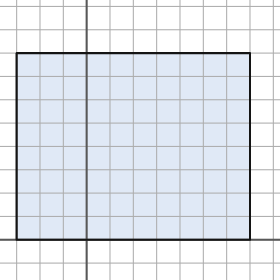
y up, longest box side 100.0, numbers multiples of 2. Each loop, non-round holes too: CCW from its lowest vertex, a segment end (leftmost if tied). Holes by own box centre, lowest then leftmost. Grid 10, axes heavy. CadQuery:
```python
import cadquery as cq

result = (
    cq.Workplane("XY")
    .moveTo(-30.0, 0.0)
    .lineTo(70.0, 0.0)
    .lineTo(70.0, 80.0)
    .lineTo(-30.0, 80.0)
    .close()
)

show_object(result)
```